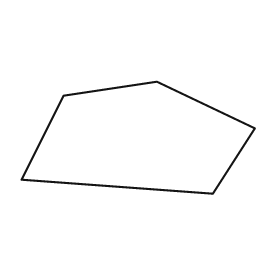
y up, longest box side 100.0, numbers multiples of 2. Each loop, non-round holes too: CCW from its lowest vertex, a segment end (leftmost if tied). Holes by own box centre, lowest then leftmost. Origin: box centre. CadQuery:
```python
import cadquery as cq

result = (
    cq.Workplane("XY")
    .moveTo(32.0, -24.0)
    .lineTo(50.0, 4.0)
    .lineTo(8.0, 24.0)
    .lineTo(-32.0, 18.0)
    .lineTo(-50.0, -18.0)
    .close()
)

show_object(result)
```